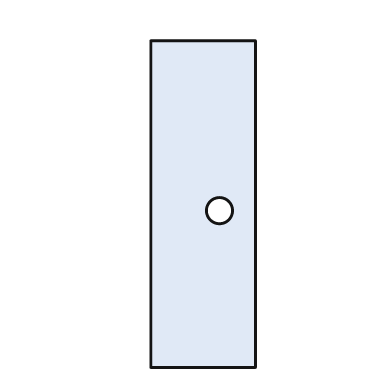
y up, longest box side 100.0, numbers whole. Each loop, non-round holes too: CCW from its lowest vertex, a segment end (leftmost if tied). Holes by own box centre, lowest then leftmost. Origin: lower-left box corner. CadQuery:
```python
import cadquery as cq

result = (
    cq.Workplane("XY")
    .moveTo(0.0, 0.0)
    .lineTo(32.0, 0.0)
    .lineTo(32.0, 100.0)
    .lineTo(0.0, 100.0)
    .close()
    .moveTo(21.0, 48.0)
    .circle(4.0)
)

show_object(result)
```